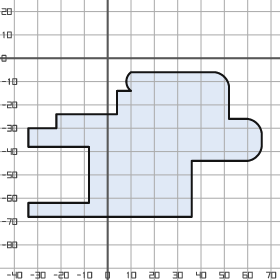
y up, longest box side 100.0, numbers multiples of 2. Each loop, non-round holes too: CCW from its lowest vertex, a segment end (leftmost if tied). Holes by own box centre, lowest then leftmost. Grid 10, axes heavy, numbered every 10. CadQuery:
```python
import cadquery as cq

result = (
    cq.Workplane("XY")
    .moveTo(-34.0, -68.0)
    .lineTo(36.0, -68.0)
    .lineTo(36.0, -44.0)
    .lineTo(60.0, -44.0)
    .threePointArc((64.0, -42.0), (66.0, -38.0))
    .lineTo(66.0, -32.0)
    .threePointArc((64.0, -28.0), (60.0, -26.0))
    .lineTo(52.0, -26.0)
    .lineTo(52.0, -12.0)
    .threePointArc((50.0, -8.0), (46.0, -6.0))
    .lineTo(10.0, -6.0)
    .threePointArc((8.0, -10.0), (10.0, -14.0))
    .lineTo(4.0, -14.0)
    .lineTo(4.0, -24.0)
    .lineTo(-22.0, -24.0)
    .lineTo(-22.0, -30.0)
    .lineTo(-34.0, -30.0)
    .lineTo(-34.0, -38.0)
    .lineTo(-8.0, -38.0)
    .lineTo(-8.0, -62.0)
    .lineTo(-34.0, -62.0)
    .close()
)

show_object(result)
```